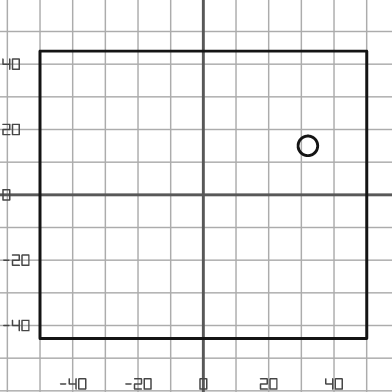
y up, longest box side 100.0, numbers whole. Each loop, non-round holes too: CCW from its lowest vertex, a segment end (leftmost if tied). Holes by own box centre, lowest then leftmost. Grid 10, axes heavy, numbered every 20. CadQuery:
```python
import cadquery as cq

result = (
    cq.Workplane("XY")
    .moveTo(-50.0, -44.0)
    .lineTo(50.0, -44.0)
    .lineTo(50.0, 44.0)
    .lineTo(-50.0, 44.0)
    .close()
    .moveTo(32.0, 15.0)
    .circle(3.0)
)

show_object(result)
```